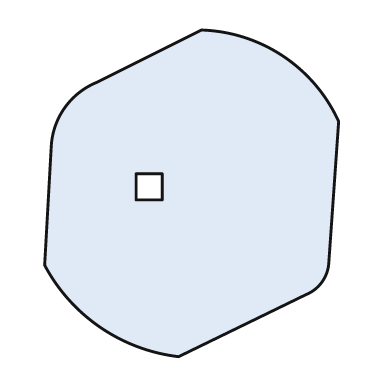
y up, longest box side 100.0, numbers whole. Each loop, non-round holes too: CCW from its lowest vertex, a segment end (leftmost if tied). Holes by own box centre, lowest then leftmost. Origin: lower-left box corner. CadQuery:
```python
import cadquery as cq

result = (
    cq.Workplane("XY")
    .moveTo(41.0, 0.0)
    .lineTo(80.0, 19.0)
    .threePointArc((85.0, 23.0), (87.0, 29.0))
    .lineTo(90.0, 72.0)
    .threePointArc((73.0, 92.0), (48.0, 100.0))
    .lineTo(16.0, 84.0)
    .threePointArc((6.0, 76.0), (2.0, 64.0))
    .lineTo(0.0, 28.0)
    .threePointArc((17.0, 9.0), (41.0, 0.0))
    .close()
    .moveTo(28.0, 48.0)
    .lineTo(36.0, 48.0)
    .lineTo(36.0, 56.0)
    .lineTo(28.0, 56.0)
    .close()
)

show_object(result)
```